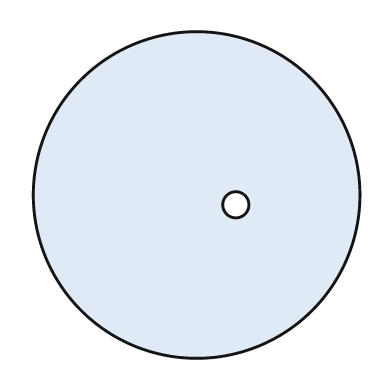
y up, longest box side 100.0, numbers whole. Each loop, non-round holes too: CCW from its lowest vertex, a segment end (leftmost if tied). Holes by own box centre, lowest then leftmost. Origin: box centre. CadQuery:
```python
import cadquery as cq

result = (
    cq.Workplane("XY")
    .moveTo(0.0, 0.0)
    .circle(50.0)
    .moveTo(12.0, -3.0)
    .circle(4.0)
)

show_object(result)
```